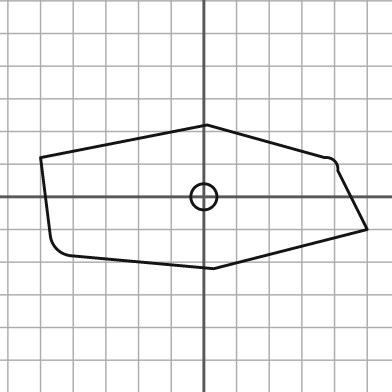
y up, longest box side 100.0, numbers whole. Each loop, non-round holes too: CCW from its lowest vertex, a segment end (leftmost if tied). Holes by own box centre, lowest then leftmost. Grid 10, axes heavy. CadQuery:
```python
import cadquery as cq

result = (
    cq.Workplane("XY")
    .moveTo(3.0, -22.0)
    .lineTo(50.0, -10.0)
    .lineTo(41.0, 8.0)
    .threePointArc((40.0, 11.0), (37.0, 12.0))
    .lineTo(1.0, 22.0)
    .lineTo(-50.0, 12.0)
    .lineTo(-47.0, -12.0)
    .threePointArc((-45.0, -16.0), (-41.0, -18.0))
    .close()
    .moveTo(0.0, 0.0)
    .circle(4.0)
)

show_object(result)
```